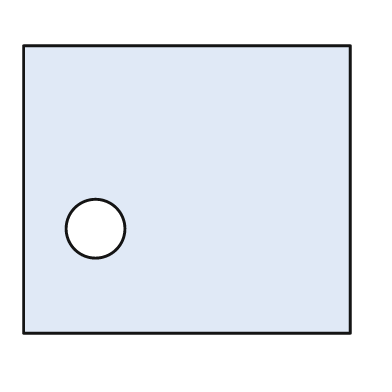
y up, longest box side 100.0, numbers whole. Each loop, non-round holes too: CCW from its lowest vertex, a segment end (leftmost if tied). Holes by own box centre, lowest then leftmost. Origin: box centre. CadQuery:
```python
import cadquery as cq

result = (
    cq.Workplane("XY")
    .moveTo(-50.0, -44.0)
    .lineTo(50.0, -44.0)
    .lineTo(50.0, 44.0)
    .lineTo(-50.0, 44.0)
    .close()
    .moveTo(-28.0, -12.0)
    .circle(9.0)
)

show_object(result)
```